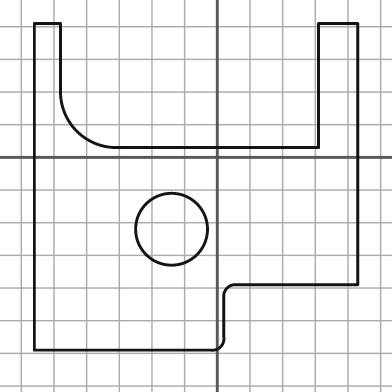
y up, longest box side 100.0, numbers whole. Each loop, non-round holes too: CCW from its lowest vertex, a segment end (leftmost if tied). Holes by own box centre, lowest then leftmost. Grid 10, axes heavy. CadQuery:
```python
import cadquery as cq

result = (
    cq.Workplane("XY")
    .moveTo(-56.0, -59.0)
    .lineTo(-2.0, -59.0)
    .threePointArc((1.0, -58.0), (2.0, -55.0))
    .lineTo(2.0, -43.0)
    .threePointArc((3.0, -40.0), (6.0, -39.0))
    .lineTo(43.0, -39.0)
    .lineTo(43.0, 41.0)
    .lineTo(31.0, 41.0)
    .lineTo(31.0, 3.0)
    .lineTo(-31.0, 3.0)
    .threePointArc((-43.0, 8.0), (-48.0, 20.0))
    .lineTo(-48.0, 41.0)
    .lineTo(-56.0, 41.0)
    .close()
    .moveTo(-14.0, -22.0)
    .circle(11.0)
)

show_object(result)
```